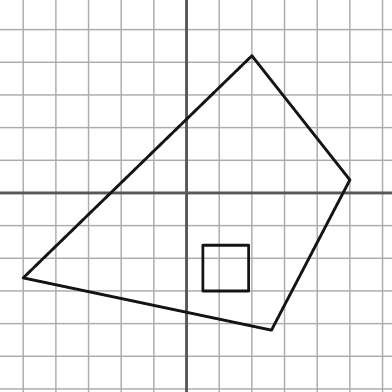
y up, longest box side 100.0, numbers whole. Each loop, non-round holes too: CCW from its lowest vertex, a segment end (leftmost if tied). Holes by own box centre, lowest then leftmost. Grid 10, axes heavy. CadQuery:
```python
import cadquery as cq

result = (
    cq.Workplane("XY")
    .moveTo(26.0, -42.0)
    .lineTo(50.0, 4.0)
    .lineTo(20.0, 42.0)
    .lineTo(-50.0, -26.0)
    .close()
    .moveTo(5.0, -30.0)
    .lineTo(19.0, -30.0)
    .lineTo(19.0, -16.0)
    .lineTo(5.0, -16.0)
    .close()
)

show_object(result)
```